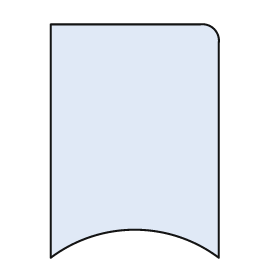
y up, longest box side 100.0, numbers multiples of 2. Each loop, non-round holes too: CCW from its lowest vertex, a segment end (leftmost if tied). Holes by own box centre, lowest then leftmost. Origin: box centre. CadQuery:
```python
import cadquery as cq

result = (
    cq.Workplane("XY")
    .moveTo(-36.0, -50.0)
    .threePointArc((0.0, -38.0), (36.0, -50.0))
    .lineTo(36.0, 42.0)
    .threePointArc((34.0, 48.0), (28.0, 50.0))
    .lineTo(-36.0, 50.0)
    .close()
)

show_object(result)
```